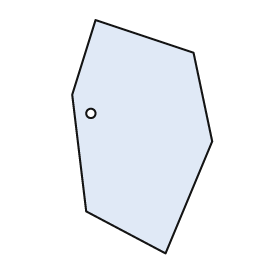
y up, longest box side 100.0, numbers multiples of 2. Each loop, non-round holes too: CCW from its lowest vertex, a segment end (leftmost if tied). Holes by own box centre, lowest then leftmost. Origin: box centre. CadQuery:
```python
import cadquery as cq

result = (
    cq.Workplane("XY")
    .moveTo(10.0, -50.0)
    .lineTo(30.0, -2.0)
    .lineTo(22.0, 36.0)
    .lineTo(-20.0, 50.0)
    .lineTo(-30.0, 18.0)
    .lineTo(-24.0, -32.0)
    .close()
    .moveTo(-22.0, 10.0)
    .circle(2.0)
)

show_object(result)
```